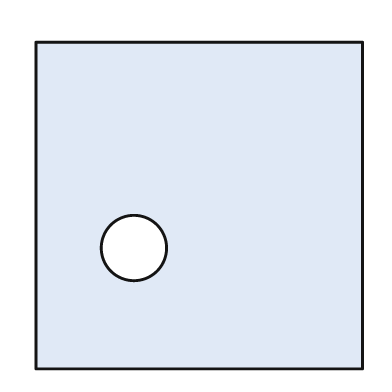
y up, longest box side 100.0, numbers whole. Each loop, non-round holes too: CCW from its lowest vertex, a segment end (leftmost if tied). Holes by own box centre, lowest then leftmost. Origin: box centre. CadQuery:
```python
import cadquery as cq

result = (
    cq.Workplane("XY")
    .moveTo(-50.0, -50.0)
    .lineTo(50.0, -50.0)
    .lineTo(50.0, 50.0)
    .lineTo(-50.0, 50.0)
    .close()
    .moveTo(-20.0, -13.0)
    .circle(10.0)
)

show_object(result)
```